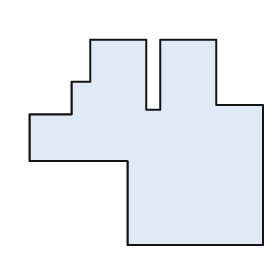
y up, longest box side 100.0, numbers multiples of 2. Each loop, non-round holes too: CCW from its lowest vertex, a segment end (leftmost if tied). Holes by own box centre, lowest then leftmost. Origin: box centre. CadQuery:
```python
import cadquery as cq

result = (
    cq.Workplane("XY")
    .moveTo(-8.0, -44.0)
    .lineTo(50.0, -44.0)
    .lineTo(50.0, 16.0)
    .lineTo(30.0, 16.0)
    .lineTo(30.0, 44.0)
    .lineTo(6.0, 44.0)
    .lineTo(6.0, 14.0)
    .lineTo(0.0, 14.0)
    .lineTo(0.0, 44.0)
    .lineTo(-24.0, 44.0)
    .lineTo(-24.0, 26.0)
    .lineTo(-32.0, 26.0)
    .lineTo(-32.0, 12.0)
    .lineTo(-50.0, 12.0)
    .lineTo(-50.0, -8.0)
    .lineTo(-8.0, -8.0)
    .close()
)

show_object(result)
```